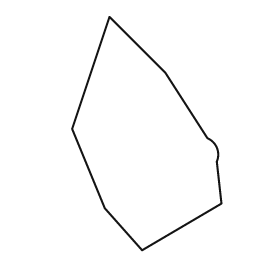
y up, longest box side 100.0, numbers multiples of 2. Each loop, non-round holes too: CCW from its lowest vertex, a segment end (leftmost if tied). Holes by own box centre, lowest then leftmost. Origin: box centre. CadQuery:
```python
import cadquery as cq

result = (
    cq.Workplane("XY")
    .moveTo(-2.0, -50.0)
    .lineTo(32.0, -30.0)
    .lineTo(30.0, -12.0)
    .threePointArc((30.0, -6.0), (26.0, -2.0))
    .lineTo(8.0, 26.0)
    .lineTo(-16.0, 50.0)
    .lineTo(-32.0, 2.0)
    .lineTo(-18.0, -32.0)
    .close()
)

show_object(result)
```